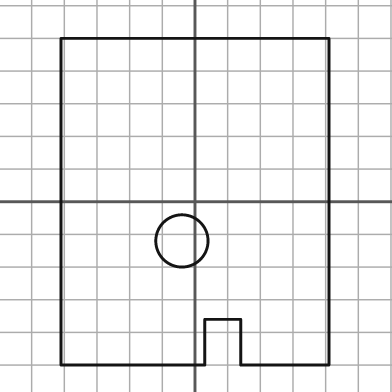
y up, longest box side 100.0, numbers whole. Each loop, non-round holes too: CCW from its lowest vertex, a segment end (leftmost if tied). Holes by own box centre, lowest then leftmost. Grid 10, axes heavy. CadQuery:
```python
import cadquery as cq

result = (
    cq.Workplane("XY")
    .moveTo(-41.0, -50.0)
    .lineTo(3.0, -50.0)
    .lineTo(3.0, -36.0)
    .lineTo(14.0, -36.0)
    .lineTo(14.0, -50.0)
    .lineTo(41.0, -50.0)
    .lineTo(41.0, 50.0)
    .lineTo(-41.0, 50.0)
    .close()
    .moveTo(-4.0, -12.0)
    .circle(8.0)
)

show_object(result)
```